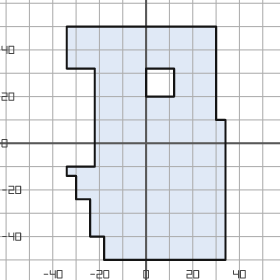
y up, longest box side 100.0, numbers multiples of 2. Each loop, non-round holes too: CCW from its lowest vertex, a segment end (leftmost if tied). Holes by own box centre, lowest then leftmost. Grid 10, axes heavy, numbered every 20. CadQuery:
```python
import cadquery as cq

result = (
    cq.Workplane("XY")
    .moveTo(-18.0, -50.0)
    .lineTo(34.0, -50.0)
    .lineTo(34.0, 10.0)
    .lineTo(30.0, 10.0)
    .lineTo(30.0, 50.0)
    .lineTo(-34.0, 50.0)
    .lineTo(-34.0, 32.0)
    .lineTo(-22.0, 32.0)
    .lineTo(-22.0, -10.0)
    .lineTo(-34.0, -10.0)
    .lineTo(-34.0, -14.0)
    .lineTo(-30.0, -14.0)
    .lineTo(-30.0, -24.0)
    .lineTo(-24.0, -24.0)
    .lineTo(-24.0, -40.0)
    .lineTo(-18.0, -40.0)
    .close()
    .moveTo(0.0, 20.0)
    .lineTo(12.0, 20.0)
    .lineTo(12.0, 32.0)
    .lineTo(0.0, 32.0)
    .close()
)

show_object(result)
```